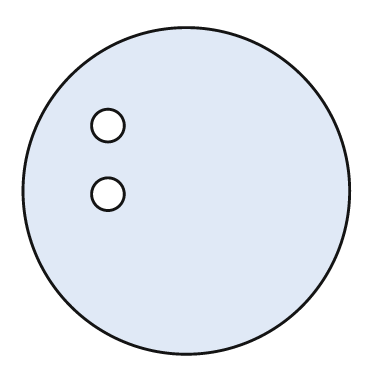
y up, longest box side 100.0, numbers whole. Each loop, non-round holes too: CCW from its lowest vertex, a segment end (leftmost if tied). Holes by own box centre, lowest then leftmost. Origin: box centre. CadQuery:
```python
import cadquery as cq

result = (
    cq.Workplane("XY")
    .moveTo(0.0, 0.0)
    .circle(50.0)
    .moveTo(-24.0, -1.0)
    .circle(5.0)
    .moveTo(-24.0, 20.0)
    .circle(5.0)
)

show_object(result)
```